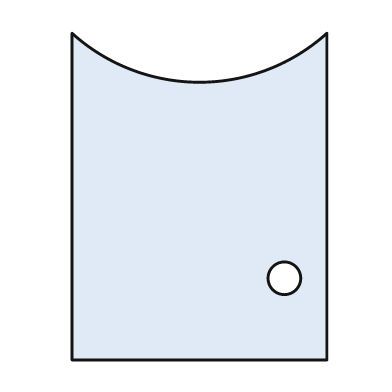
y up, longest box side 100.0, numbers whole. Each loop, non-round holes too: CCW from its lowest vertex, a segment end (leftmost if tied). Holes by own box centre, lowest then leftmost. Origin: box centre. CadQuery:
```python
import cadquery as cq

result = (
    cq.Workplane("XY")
    .moveTo(-39.0, -50.0)
    .lineTo(39.0, -50.0)
    .lineTo(39.0, 50.0)
    .threePointArc((0.0, 35.0), (-39.0, 50.0))
    .close()
    .moveTo(26.0, -25.0)
    .circle(5.0)
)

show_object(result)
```